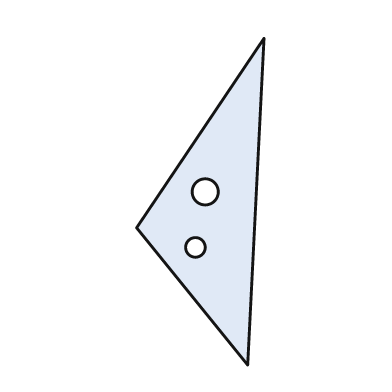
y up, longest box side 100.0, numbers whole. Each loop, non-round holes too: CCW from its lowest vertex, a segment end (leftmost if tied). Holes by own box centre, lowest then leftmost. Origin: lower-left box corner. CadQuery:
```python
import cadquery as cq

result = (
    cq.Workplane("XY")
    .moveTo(34.0, 0.0)
    .lineTo(39.0, 100.0)
    .lineTo(0.0, 42.0)
    .close()
    .moveTo(18.0, 36.0)
    .circle(3.0)
    .moveTo(21.0, 53.0)
    .circle(4.0)
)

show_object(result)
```